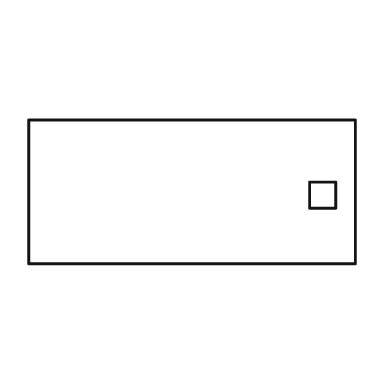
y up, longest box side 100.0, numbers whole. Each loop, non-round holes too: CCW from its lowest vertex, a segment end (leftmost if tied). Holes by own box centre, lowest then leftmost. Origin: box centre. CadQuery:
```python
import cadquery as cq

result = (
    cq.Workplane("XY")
    .moveTo(-50.0, -22.0)
    .lineTo(50.0, -22.0)
    .lineTo(50.0, 22.0)
    .lineTo(-50.0, 22.0)
    .close()
    .moveTo(36.0, -5.0)
    .lineTo(44.0, -5.0)
    .lineTo(44.0, 3.0)
    .lineTo(36.0, 3.0)
    .close()
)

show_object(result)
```